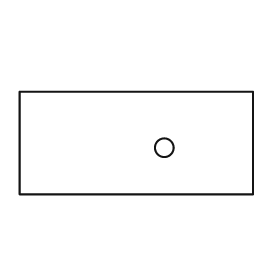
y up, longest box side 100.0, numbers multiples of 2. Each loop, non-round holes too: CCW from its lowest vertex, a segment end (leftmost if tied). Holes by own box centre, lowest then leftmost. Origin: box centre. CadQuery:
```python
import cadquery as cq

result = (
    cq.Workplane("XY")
    .moveTo(-50.0, -22.0)
    .lineTo(50.0, -22.0)
    .lineTo(50.0, 22.0)
    .lineTo(-50.0, 22.0)
    .close()
    .moveTo(12.0, -2.0)
    .circle(4.0)
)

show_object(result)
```